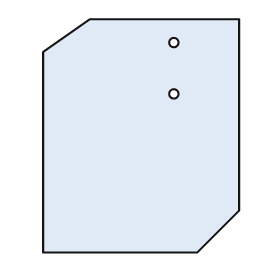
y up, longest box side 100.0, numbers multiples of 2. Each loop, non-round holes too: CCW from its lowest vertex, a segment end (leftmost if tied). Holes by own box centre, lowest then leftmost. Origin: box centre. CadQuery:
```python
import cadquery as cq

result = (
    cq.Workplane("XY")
    .moveTo(-42.0, -50.0)
    .lineTo(24.0, -50.0)
    .lineTo(42.0, -32.0)
    .lineTo(42.0, 50.0)
    .lineTo(-22.0, 50.0)
    .lineTo(-42.0, 36.0)
    .close()
    .moveTo(14.0, 18.0)
    .circle(2.0)
    .moveTo(14.0, 40.0)
    .circle(2.0)
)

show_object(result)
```